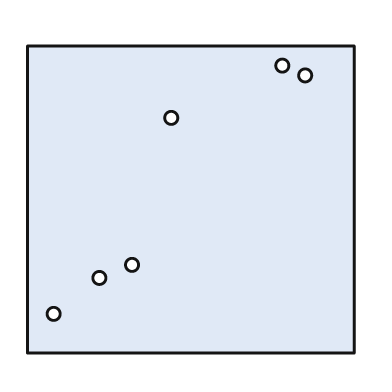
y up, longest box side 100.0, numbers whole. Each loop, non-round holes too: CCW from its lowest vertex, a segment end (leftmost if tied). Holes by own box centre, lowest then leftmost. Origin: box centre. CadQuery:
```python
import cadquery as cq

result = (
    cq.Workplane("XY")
    .moveTo(-50.0, -47.0)
    .lineTo(50.0, -47.0)
    .lineTo(50.0, 47.0)
    .lineTo(-50.0, 47.0)
    .close()
    .moveTo(-42.0, -35.0)
    .circle(2.0)
    .moveTo(-28.0, -24.0)
    .circle(2.0)
    .moveTo(-18.0, -20.0)
    .circle(2.0)
    .moveTo(-6.0, 25.0)
    .circle(2.0)
    .moveTo(35.0, 38.0)
    .circle(2.0)
    .moveTo(28.0, 41.0)
    .circle(2.0)
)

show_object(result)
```